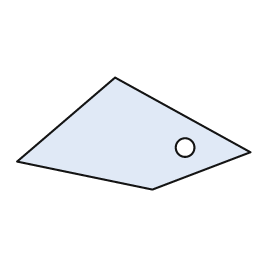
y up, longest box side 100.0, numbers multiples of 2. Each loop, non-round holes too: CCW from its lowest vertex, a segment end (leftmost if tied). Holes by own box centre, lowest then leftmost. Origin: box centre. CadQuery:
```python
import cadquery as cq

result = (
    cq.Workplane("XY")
    .moveTo(8.0, -24.0)
    .lineTo(50.0, -8.0)
    .lineTo(-8.0, 24.0)
    .lineTo(-50.0, -12.0)
    .close()
    .moveTo(22.0, -6.0)
    .circle(4.0)
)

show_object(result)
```